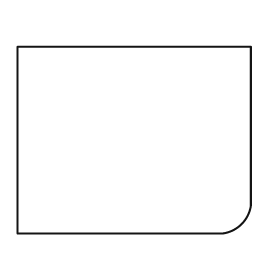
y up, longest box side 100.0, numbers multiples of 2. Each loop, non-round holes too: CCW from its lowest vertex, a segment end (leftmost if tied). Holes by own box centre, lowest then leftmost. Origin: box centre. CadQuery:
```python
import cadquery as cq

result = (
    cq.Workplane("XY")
    .moveTo(-50.0, -40.0)
    .lineTo(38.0, -40.0)
    .threePointArc((46.0, -36.0), (50.0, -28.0))
    .lineTo(50.0, 40.0)
    .lineTo(-50.0, 40.0)
    .close()
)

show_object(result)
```